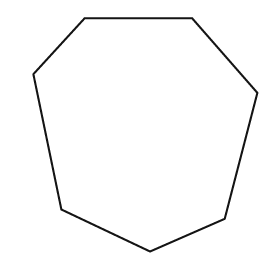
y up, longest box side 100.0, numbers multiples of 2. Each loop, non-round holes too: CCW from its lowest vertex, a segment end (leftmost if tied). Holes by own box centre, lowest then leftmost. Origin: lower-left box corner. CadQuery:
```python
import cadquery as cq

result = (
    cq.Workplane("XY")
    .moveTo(50.0, 0.0)
    .lineTo(82.0, 14.0)
    .lineTo(96.0, 68.0)
    .lineTo(68.0, 100.0)
    .lineTo(22.0, 100.0)
    .lineTo(0.0, 76.0)
    .lineTo(12.0, 18.0)
    .close()
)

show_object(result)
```